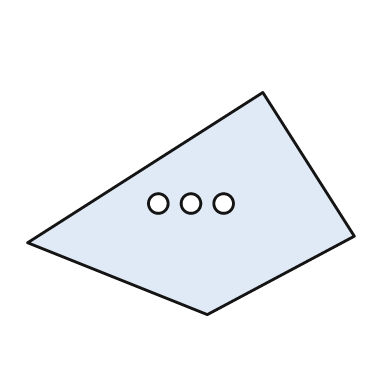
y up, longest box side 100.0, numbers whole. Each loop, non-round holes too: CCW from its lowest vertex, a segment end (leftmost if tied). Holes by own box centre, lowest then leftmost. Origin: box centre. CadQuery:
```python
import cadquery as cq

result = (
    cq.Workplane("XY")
    .moveTo(5.0, -34.0)
    .lineTo(50.0, -10.0)
    .lineTo(22.0, 34.0)
    .lineTo(-50.0, -12.0)
    .close()
    .moveTo(-10.0, 0.0)
    .circle(3.0)
    .moveTo(0.0, 0.0)
    .circle(3.0)
    .moveTo(10.0, 0.0)
    .circle(3.0)
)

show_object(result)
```